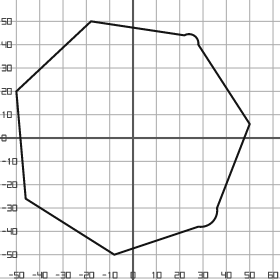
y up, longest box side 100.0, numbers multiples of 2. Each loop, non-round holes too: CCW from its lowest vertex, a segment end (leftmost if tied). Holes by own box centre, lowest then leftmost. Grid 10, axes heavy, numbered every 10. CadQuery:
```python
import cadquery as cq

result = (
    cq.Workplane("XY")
    .moveTo(-8.0, -50.0)
    .lineTo(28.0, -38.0)
    .threePointArc((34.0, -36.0), (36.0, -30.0))
    .lineTo(50.0, 6.0)
    .lineTo(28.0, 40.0)
    .threePointArc((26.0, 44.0), (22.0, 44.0))
    .lineTo(-18.0, 50.0)
    .lineTo(-50.0, 20.0)
    .lineTo(-46.0, -26.0)
    .close()
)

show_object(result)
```